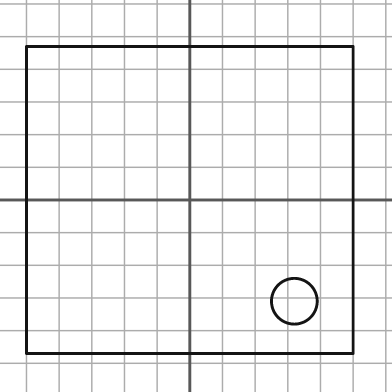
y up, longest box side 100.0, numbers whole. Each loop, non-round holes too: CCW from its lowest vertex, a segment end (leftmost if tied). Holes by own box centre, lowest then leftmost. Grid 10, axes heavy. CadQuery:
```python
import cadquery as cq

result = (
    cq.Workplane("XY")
    .moveTo(-50.0, -47.0)
    .lineTo(50.0, -47.0)
    .lineTo(50.0, 47.0)
    .lineTo(-50.0, 47.0)
    .close()
    .moveTo(32.0, -31.0)
    .circle(7.0)
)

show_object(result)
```